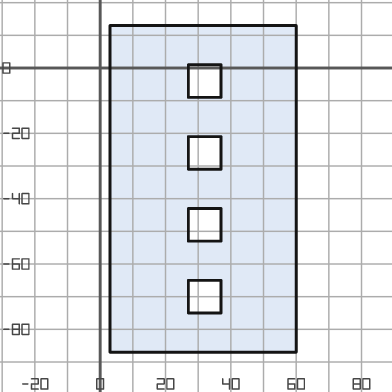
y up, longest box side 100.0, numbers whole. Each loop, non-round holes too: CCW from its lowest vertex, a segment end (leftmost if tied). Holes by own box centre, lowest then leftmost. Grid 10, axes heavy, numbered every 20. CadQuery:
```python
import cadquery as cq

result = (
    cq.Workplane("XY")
    .moveTo(3.0, -87.0)
    .lineTo(60.0, -87.0)
    .lineTo(60.0, 13.0)
    .lineTo(3.0, 13.0)
    .close()
    .moveTo(27.0, -75.0)
    .lineTo(37.0, -75.0)
    .lineTo(37.0, -65.0)
    .lineTo(27.0, -65.0)
    .close()
    .moveTo(27.0, -53.0)
    .lineTo(37.0, -53.0)
    .lineTo(37.0, -43.0)
    .lineTo(27.0, -43.0)
    .close()
    .moveTo(27.0, -31.0)
    .lineTo(37.0, -31.0)
    .lineTo(37.0, -21.0)
    .lineTo(27.0, -21.0)
    .close()
    .moveTo(27.0, -9.0)
    .lineTo(37.0, -9.0)
    .lineTo(37.0, 1.0)
    .lineTo(27.0, 1.0)
    .close()
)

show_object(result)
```